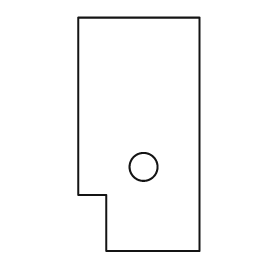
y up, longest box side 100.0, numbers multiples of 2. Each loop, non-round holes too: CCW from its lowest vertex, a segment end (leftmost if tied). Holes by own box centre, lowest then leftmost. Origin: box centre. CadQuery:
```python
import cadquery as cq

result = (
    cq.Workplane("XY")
    .moveTo(-14.0, -50.0)
    .lineTo(26.0, -50.0)
    .lineTo(26.0, 50.0)
    .lineTo(-26.0, 50.0)
    .lineTo(-26.0, -26.0)
    .lineTo(-14.0, -26.0)
    .close()
    .moveTo(2.0, -14.0)
    .circle(6.0)
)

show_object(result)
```